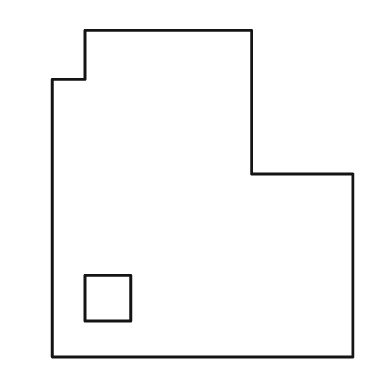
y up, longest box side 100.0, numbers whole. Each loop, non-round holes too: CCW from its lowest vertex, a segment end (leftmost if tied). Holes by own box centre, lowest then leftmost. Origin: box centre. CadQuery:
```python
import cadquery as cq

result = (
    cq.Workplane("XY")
    .moveTo(-46.0, -50.0)
    .lineTo(46.0, -50.0)
    .lineTo(46.0, 6.0)
    .lineTo(15.0, 6.0)
    .lineTo(15.0, 50.0)
    .lineTo(-36.0, 50.0)
    .lineTo(-36.0, 35.0)
    .lineTo(-46.0, 35.0)
    .close()
    .moveTo(-36.0, -39.0)
    .lineTo(-22.0, -39.0)
    .lineTo(-22.0, -25.0)
    .lineTo(-36.0, -25.0)
    .close()
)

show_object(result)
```